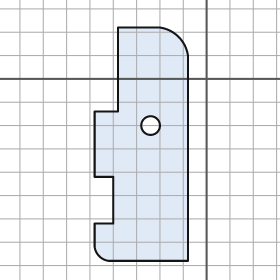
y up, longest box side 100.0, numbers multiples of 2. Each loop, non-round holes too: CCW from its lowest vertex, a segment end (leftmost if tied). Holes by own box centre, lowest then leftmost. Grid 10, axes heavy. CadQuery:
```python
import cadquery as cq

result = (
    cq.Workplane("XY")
    .moveTo(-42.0, -78.0)
    .lineTo(-8.0, -78.0)
    .lineTo(-8.0, 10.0)
    .threePointArc((-12.0, 18.0), (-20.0, 22.0))
    .lineTo(-38.0, 22.0)
    .lineTo(-38.0, -14.0)
    .lineTo(-48.0, -14.0)
    .lineTo(-48.0, -42.0)
    .lineTo(-40.0, -42.0)
    .lineTo(-40.0, -62.0)
    .lineTo(-48.0, -62.0)
    .lineTo(-48.0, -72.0)
    .threePointArc((-46.0, -76.0), (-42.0, -78.0))
    .close()
    .moveTo(-24.0, -20.0)
    .circle(4.0)
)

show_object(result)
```